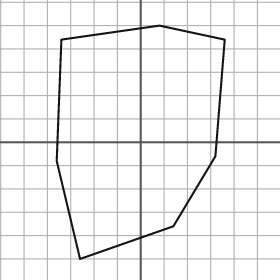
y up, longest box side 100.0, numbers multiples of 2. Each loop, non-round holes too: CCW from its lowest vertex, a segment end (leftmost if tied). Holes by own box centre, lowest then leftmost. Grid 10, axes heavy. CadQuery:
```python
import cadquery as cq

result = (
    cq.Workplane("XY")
    .moveTo(-26.0, -50.0)
    .lineTo(14.0, -36.0)
    .lineTo(32.0, -6.0)
    .lineTo(36.0, 44.0)
    .lineTo(8.0, 50.0)
    .lineTo(-34.0, 44.0)
    .lineTo(-36.0, -8.0)
    .close()
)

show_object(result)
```